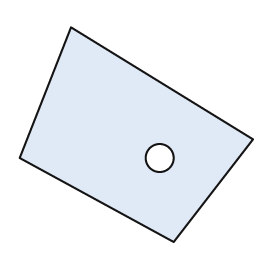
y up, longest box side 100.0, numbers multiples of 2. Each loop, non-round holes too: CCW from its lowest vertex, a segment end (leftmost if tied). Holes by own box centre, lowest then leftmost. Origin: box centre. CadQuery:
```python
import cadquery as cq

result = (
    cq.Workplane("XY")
    .moveTo(16.0, -46.0)
    .lineTo(50.0, -2.0)
    .lineTo(-28.0, 46.0)
    .lineTo(-50.0, -10.0)
    .close()
    .moveTo(10.0, -10.0)
    .circle(6.0)
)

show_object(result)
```